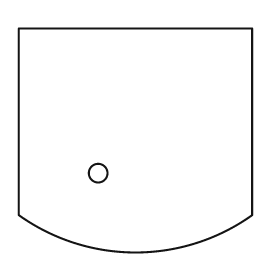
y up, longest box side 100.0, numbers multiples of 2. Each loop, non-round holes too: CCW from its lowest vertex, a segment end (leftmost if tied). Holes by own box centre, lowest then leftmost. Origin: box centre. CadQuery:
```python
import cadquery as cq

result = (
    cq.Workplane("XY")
    .moveTo(-50.0, -32.0)
    .threePointArc((0.0, -48.0), (50.0, -32.0))
    .lineTo(50.0, 48.0)
    .lineTo(-50.0, 48.0)
    .close()
    .moveTo(-16.0, -14.0)
    .circle(4.0)
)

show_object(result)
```